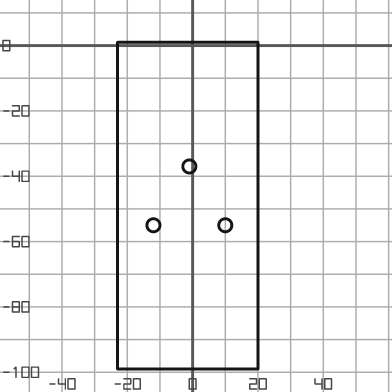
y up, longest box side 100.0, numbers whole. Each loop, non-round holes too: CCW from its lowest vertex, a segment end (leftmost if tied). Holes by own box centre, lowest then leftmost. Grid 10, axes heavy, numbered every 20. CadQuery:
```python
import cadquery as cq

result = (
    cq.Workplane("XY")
    .moveTo(-23.0, -99.0)
    .lineTo(20.0, -99.0)
    .lineTo(20.0, 1.0)
    .lineTo(-23.0, 1.0)
    .close()
    .moveTo(-12.0, -55.0)
    .circle(2.0)
    .moveTo(10.0, -55.0)
    .circle(2.0)
    .moveTo(-1.0, -37.0)
    .circle(2.0)
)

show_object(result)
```